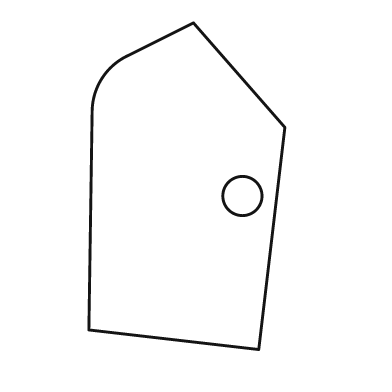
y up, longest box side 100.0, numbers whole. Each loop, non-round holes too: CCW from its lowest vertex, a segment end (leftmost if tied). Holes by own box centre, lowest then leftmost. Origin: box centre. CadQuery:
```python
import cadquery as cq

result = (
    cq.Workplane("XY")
    .moveTo(22.0, -50.0)
    .lineTo(30.0, 18.0)
    .lineTo(2.0, 50.0)
    .lineTo(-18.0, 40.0)
    .threePointArc((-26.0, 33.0), (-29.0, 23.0))
    .lineTo(-30.0, -44.0)
    .close()
    .moveTo(17.0, -3.0)
    .circle(6.0)
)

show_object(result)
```